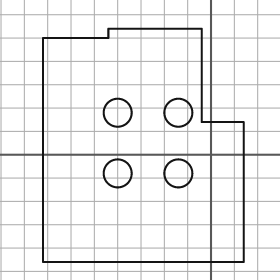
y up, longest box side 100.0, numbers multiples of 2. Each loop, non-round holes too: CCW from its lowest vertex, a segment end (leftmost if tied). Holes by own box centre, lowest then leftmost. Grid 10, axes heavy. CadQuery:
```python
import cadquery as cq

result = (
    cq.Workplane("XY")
    .moveTo(-72.0, -46.0)
    .lineTo(14.0, -46.0)
    .lineTo(14.0, 14.0)
    .lineTo(-4.0, 14.0)
    .lineTo(-4.0, 54.0)
    .lineTo(-44.0, 54.0)
    .lineTo(-44.0, 50.0)
    .lineTo(-72.0, 50.0)
    .close()
    .moveTo(-40.0, -8.0)
    .circle(6.0)
    .moveTo(-14.0, -8.0)
    .circle(6.0)
    .moveTo(-40.0, 18.0)
    .circle(6.0)
    .moveTo(-14.0, 18.0)
    .circle(6.0)
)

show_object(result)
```